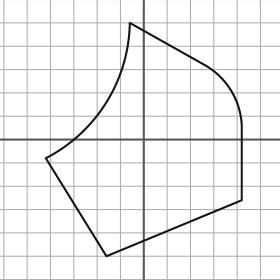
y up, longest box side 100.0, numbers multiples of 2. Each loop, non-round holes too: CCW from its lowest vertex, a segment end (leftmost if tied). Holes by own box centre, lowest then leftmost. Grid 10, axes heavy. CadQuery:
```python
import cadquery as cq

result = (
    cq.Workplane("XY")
    .moveTo(-16.0, -50.0)
    .lineTo(42.0, -26.0)
    .lineTo(42.0, 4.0)
    .threePointArc((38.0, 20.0), (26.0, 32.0))
    .lineTo(-6.0, 50.0)
    .threePointArc((-16.0, 16.0), (-42.0, -8.0))
    .close()
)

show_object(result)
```